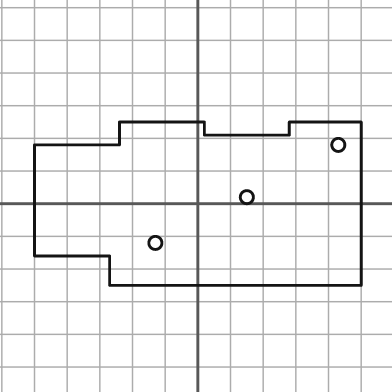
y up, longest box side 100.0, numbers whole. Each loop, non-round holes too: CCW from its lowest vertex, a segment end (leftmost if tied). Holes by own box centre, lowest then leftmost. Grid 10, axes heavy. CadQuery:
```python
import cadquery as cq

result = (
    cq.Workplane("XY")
    .moveTo(-27.0, -25.0)
    .lineTo(50.0, -25.0)
    .lineTo(50.0, 25.0)
    .lineTo(28.0, 25.0)
    .lineTo(28.0, 21.0)
    .lineTo(2.0, 21.0)
    .lineTo(2.0, 25.0)
    .lineTo(-24.0, 25.0)
    .lineTo(-24.0, 18.0)
    .lineTo(-50.0, 18.0)
    .lineTo(-50.0, -16.0)
    .lineTo(-27.0, -16.0)
    .close()
    .moveTo(-13.0, -12.0)
    .circle(2.0)
    .moveTo(15.0, 2.0)
    .circle(2.0)
    .moveTo(43.0, 18.0)
    .circle(2.0)
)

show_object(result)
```